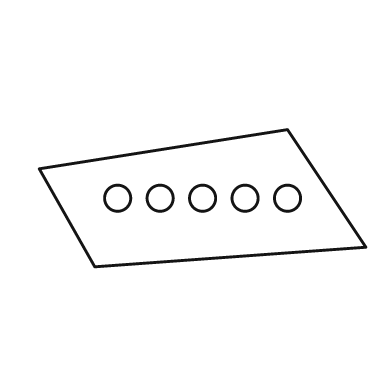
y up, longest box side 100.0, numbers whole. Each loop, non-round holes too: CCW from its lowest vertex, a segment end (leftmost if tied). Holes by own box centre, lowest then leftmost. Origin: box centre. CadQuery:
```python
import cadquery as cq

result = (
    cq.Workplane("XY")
    .moveTo(-33.0, -21.0)
    .lineTo(50.0, -15.0)
    .lineTo(26.0, 21.0)
    .lineTo(-50.0, 9.0)
    .close()
    .moveTo(-26.0, 0.0)
    .circle(4.0)
    .moveTo(-13.0, 0.0)
    .circle(4.0)
    .moveTo(0.0, 0.0)
    .circle(4.0)
    .moveTo(13.0, 0.0)
    .circle(4.0)
    .moveTo(26.0, 0.0)
    .circle(4.0)
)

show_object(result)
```